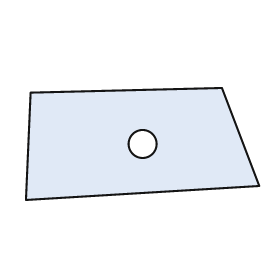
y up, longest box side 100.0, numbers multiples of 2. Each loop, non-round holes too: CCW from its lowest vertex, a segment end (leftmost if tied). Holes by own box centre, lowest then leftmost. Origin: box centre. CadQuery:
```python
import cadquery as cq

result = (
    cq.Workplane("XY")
    .moveTo(-50.0, -24.0)
    .lineTo(50.0, -18.0)
    .lineTo(34.0, 24.0)
    .lineTo(-48.0, 22.0)
    .close()
    .moveTo(0.0, 0.0)
    .circle(6.0)
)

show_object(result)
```